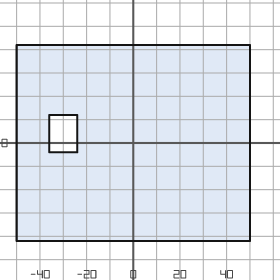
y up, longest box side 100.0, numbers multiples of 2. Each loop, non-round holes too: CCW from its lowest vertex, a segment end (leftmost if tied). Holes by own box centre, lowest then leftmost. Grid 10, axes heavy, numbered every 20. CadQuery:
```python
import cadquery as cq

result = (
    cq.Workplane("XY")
    .moveTo(-50.0, -42.0)
    .lineTo(50.0, -42.0)
    .lineTo(50.0, 42.0)
    .lineTo(-50.0, 42.0)
    .close()
    .moveTo(-36.0, -4.0)
    .lineTo(-24.0, -4.0)
    .lineTo(-24.0, 12.0)
    .lineTo(-36.0, 12.0)
    .close()
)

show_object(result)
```